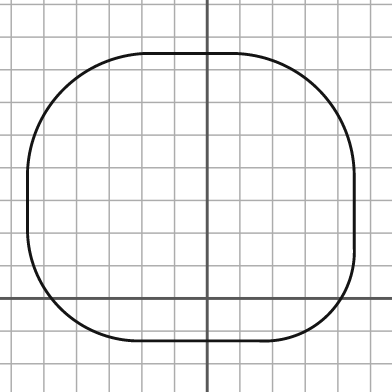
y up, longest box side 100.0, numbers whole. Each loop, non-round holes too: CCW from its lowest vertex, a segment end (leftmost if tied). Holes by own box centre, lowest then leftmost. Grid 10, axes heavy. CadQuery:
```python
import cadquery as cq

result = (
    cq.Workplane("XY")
    .moveTo(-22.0, -13.0)
    .lineTo(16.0, -13.0)
    .threePointArc((37.0, -5.0), (45.0, 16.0))
    .lineTo(45.0, 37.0)
    .threePointArc((34.0, 64.0), (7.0, 75.0))
    .lineTo(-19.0, 75.0)
    .threePointArc((-44.0, 64.0), (-55.0, 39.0))
    .lineTo(-55.0, 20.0)
    .threePointArc((-45.0, -3.0), (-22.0, -13.0))
    .close()
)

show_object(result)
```